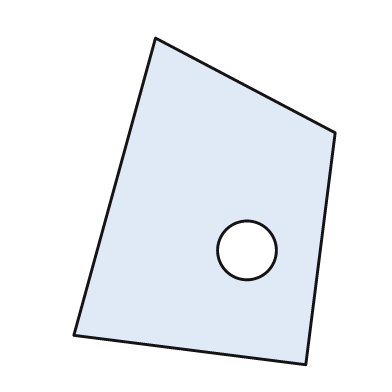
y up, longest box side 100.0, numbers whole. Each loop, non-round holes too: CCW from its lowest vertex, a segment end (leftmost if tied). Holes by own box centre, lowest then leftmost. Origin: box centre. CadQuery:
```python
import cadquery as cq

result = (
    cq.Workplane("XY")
    .moveTo(31.0, -50.0)
    .lineTo(40.0, 21.0)
    .lineTo(-15.0, 50.0)
    .lineTo(-40.0, -41.0)
    .close()
    .moveTo(13.0, -15.0)
    .circle(9.0)
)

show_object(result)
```